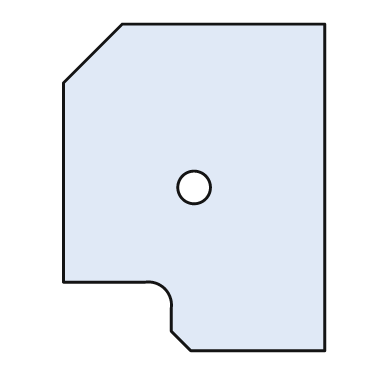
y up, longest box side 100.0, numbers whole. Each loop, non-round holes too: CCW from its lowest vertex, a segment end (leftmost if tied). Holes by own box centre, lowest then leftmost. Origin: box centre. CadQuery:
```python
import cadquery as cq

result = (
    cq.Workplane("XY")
    .moveTo(-1.0, -50.0)
    .lineTo(40.0, -50.0)
    .lineTo(40.0, 50.0)
    .lineTo(-22.0, 50.0)
    .lineTo(-40.0, 32.0)
    .lineTo(-40.0, -29.0)
    .lineTo(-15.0, -29.0)
    .threePointArc((-9.0, -31.0), (-7.0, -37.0))
    .lineTo(-7.0, -44.0)
    .close()
    .moveTo(0.0, 0.0)
    .circle(5.0)
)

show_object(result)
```